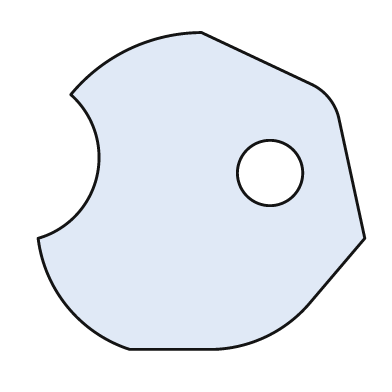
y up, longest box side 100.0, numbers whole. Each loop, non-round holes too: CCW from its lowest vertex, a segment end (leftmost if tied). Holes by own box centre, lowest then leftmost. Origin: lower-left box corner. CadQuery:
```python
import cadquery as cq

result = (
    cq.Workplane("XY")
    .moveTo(28.0, 0.0)
    .lineTo(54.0, 0.0)
    .threePointArc((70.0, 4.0), (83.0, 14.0))
    .lineTo(100.0, 34.0)
    .lineTo(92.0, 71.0)
    .threePointArc((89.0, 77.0), (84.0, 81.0))
    .lineTo(50.0, 97.0)
    .threePointArc((28.0, 92.0), (10.0, 78.0))
    .threePointArc((18.0, 53.0), (0.0, 34.0))
    .threePointArc((9.0, 13.0), (28.0, 0.0))
    .close()
    .moveTo(71.0, 54.0)
    .circle(10.0)
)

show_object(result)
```